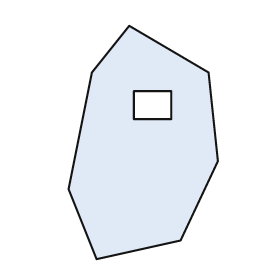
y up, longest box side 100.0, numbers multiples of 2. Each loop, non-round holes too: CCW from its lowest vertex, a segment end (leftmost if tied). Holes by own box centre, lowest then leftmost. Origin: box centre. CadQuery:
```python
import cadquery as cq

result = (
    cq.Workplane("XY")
    .moveTo(-20.0, -50.0)
    .lineTo(16.0, -42.0)
    .lineTo(32.0, -8.0)
    .lineTo(28.0, 30.0)
    .lineTo(-6.0, 50.0)
    .lineTo(-22.0, 30.0)
    .lineTo(-32.0, -20.0)
    .close()
    .moveTo(-4.0, 10.0)
    .lineTo(12.0, 10.0)
    .lineTo(12.0, 22.0)
    .lineTo(-4.0, 22.0)
    .close()
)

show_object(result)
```